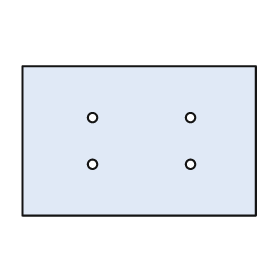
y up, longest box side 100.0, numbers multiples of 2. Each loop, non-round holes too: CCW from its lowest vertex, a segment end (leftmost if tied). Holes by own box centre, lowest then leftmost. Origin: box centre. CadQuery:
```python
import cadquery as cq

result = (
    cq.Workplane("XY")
    .moveTo(-50.0, -32.0)
    .lineTo(50.0, -32.0)
    .lineTo(50.0, 32.0)
    .lineTo(-50.0, 32.0)
    .close()
    .moveTo(-20.0, -10.0)
    .circle(2.0)
    .moveTo(22.0, -10.0)
    .circle(2.0)
    .moveTo(-20.0, 10.0)
    .circle(2.0)
    .moveTo(22.0, 10.0)
    .circle(2.0)
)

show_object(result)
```